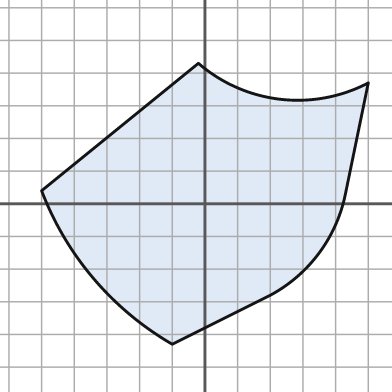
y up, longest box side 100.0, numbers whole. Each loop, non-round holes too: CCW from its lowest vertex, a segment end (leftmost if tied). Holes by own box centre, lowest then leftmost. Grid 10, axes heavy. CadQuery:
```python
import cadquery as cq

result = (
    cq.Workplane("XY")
    .moveTo(-10.0, -43.0)
    .lineTo(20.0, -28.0)
    .threePointArc((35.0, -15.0), (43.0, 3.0))
    .lineTo(50.0, 37.0)
    .threePointArc((23.0, 32.0), (-2.0, 43.0))
    .lineTo(-50.0, 4.0)
    .threePointArc((-34.0, -23.0), (-10.0, -43.0))
    .close()
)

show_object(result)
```